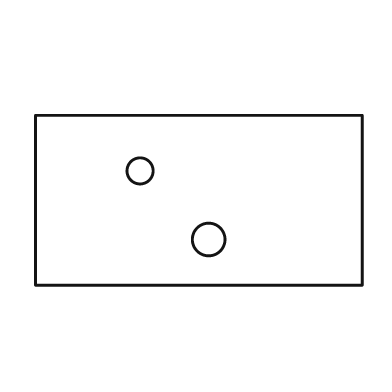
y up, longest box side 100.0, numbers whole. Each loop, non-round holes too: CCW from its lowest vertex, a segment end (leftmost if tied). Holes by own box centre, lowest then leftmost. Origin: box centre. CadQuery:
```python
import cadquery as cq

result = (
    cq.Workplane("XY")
    .moveTo(-50.0, -26.0)
    .lineTo(50.0, -26.0)
    .lineTo(50.0, 26.0)
    .lineTo(-50.0, 26.0)
    .close()
    .moveTo(3.0, -12.0)
    .circle(5.0)
    .moveTo(-18.0, 9.0)
    .circle(4.0)
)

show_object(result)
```